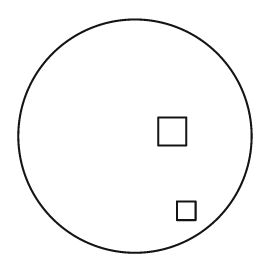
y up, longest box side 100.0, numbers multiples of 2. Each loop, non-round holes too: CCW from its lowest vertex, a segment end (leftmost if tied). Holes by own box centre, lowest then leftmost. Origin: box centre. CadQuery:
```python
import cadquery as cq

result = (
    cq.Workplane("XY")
    .moveTo(0.0, 0.0)
    .circle(50.0)
    .moveTo(18.0, -36.0)
    .lineTo(26.0, -36.0)
    .lineTo(26.0, -28.0)
    .lineTo(18.0, -28.0)
    .close()
    .moveTo(10.0, -4.0)
    .lineTo(22.0, -4.0)
    .lineTo(22.0, 8.0)
    .lineTo(10.0, 8.0)
    .close()
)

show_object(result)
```